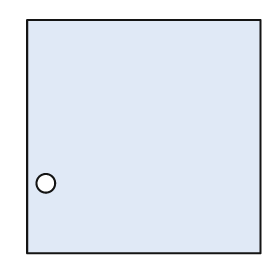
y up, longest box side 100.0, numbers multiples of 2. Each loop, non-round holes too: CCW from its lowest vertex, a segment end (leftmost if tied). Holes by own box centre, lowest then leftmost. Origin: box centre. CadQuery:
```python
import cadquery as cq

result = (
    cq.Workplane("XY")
    .moveTo(-50.0, -50.0)
    .lineTo(50.0, -50.0)
    .lineTo(50.0, 50.0)
    .lineTo(-50.0, 50.0)
    .close()
    .moveTo(-42.0, -20.0)
    .circle(4.0)
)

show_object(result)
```